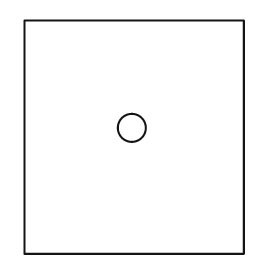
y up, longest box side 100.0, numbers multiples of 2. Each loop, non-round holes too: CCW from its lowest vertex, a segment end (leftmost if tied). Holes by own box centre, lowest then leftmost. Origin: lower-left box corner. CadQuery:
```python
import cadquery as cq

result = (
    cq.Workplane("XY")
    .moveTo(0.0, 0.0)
    .lineTo(94.0, 0.0)
    .lineTo(94.0, 100.0)
    .lineTo(0.0, 100.0)
    .close()
    .moveTo(46.0, 54.0)
    .circle(6.0)
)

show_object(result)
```